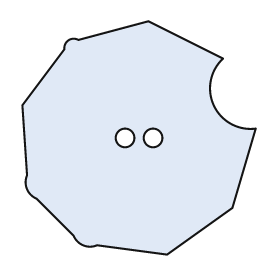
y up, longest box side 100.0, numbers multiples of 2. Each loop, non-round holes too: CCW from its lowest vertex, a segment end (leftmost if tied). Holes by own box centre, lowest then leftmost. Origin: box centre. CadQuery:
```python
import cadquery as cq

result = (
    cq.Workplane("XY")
    .moveTo(12.0, -50.0)
    .lineTo(40.0, -30.0)
    .lineTo(50.0, 4.0)
    .threePointArc((32.0, 14.0), (36.0, 34.0))
    .lineTo(4.0, 50.0)
    .lineTo(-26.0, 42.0)
    .threePointArc((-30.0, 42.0), (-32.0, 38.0))
    .lineTo(-50.0, 14.0)
    .lineTo(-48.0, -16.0)
    .threePointArc((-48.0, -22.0), (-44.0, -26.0))
    .lineTo(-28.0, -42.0)
    .threePointArc((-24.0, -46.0), (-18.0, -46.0))
    .close()
    .moveTo(-6.0, 0.0)
    .circle(4.0)
    .moveTo(6.0, 0.0)
    .circle(4.0)
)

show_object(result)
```